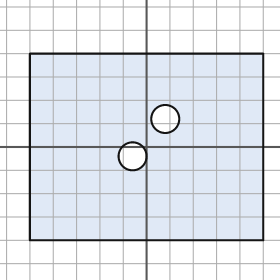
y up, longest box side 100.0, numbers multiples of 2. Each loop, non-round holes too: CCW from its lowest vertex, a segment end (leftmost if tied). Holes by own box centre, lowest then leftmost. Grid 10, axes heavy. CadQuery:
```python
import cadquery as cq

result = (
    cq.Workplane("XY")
    .moveTo(-50.0, -40.0)
    .lineTo(50.0, -40.0)
    .lineTo(50.0, 40.0)
    .lineTo(-50.0, 40.0)
    .close()
    .moveTo(-6.0, -4.0)
    .circle(6.0)
    .moveTo(8.0, 12.0)
    .circle(6.0)
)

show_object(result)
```